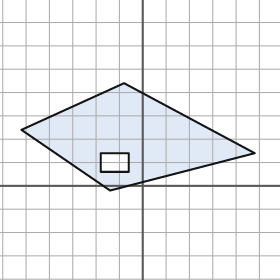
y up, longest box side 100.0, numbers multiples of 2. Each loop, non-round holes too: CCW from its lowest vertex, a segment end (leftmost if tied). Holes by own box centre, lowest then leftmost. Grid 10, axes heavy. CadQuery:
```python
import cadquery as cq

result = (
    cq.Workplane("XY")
    .moveTo(-14.0, -2.0)
    .lineTo(48.0, 14.0)
    .lineTo(-8.0, 44.0)
    .lineTo(-52.0, 24.0)
    .close()
    .moveTo(-18.0, 6.0)
    .lineTo(-6.0, 6.0)
    .lineTo(-6.0, 14.0)
    .lineTo(-18.0, 14.0)
    .close()
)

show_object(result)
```